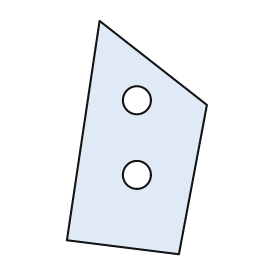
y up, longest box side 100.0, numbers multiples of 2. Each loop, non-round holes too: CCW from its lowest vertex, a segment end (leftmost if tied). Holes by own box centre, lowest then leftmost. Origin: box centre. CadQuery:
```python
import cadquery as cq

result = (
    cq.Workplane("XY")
    .moveTo(18.0, -50.0)
    .lineTo(30.0, 14.0)
    .lineTo(-16.0, 50.0)
    .lineTo(-30.0, -44.0)
    .close()
    .moveTo(0.0, -16.0)
    .circle(6.0)
    .moveTo(0.0, 16.0)
    .circle(6.0)
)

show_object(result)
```